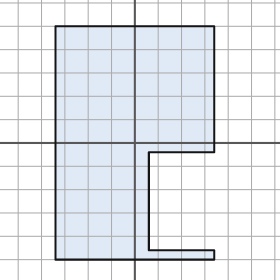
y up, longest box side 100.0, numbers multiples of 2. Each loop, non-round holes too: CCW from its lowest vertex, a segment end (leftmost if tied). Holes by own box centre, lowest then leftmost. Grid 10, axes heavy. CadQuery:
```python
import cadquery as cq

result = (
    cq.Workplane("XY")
    .moveTo(-34.0, -50.0)
    .lineTo(34.0, -50.0)
    .lineTo(34.0, -46.0)
    .lineTo(6.0, -46.0)
    .lineTo(6.0, -4.0)
    .lineTo(34.0, -4.0)
    .lineTo(34.0, 50.0)
    .lineTo(-34.0, 50.0)
    .close()
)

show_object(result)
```